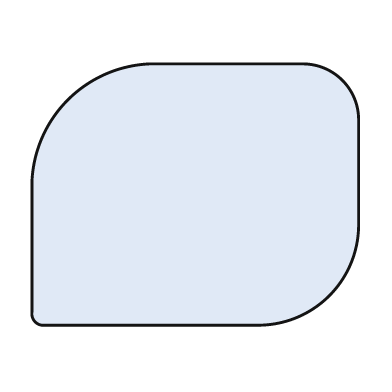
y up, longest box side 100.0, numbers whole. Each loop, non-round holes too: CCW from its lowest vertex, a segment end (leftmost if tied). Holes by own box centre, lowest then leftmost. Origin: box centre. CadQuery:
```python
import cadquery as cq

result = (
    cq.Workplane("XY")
    .moveTo(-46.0, -40.0)
    .lineTo(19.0, -40.0)
    .threePointArc((41.0, -31.0), (50.0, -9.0))
    .lineTo(50.0, 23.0)
    .threePointArc((45.0, 35.0), (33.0, 40.0))
    .lineTo(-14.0, 40.0)
    .threePointArc((-39.0, 29.0), (-50.0, 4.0))
    .lineTo(-50.0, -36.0)
    .threePointArc((-49.0, -39.0), (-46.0, -40.0))
    .close()
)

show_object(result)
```